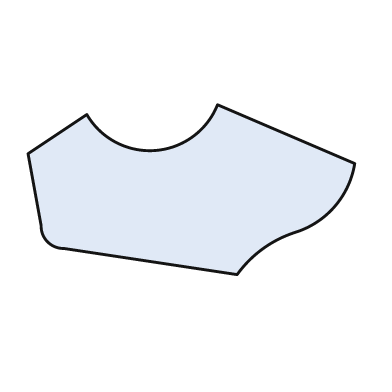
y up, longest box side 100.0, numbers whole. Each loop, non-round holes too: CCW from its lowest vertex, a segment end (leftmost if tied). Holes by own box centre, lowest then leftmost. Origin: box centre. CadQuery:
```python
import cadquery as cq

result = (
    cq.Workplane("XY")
    .moveTo(14.0, -26.0)
    .threePointArc((22.0, -18.0), (32.0, -13.0))
    .threePointArc((44.0, -5.0), (50.0, 8.0))
    .lineTo(8.0, 26.0)
    .threePointArc((-11.0, 12.0), (-32.0, 23.0))
    .lineTo(-50.0, 11.0)
    .lineTo(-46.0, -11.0)
    .threePointArc((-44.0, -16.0), (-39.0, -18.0))
    .close()
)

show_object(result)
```